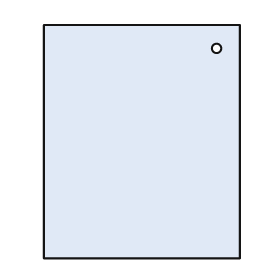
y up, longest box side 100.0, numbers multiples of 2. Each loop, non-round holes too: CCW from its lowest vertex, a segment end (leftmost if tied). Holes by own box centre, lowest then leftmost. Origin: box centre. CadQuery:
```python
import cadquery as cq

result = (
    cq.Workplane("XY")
    .moveTo(-42.0, -50.0)
    .lineTo(42.0, -50.0)
    .lineTo(42.0, 50.0)
    .lineTo(-42.0, 50.0)
    .close()
    .moveTo(32.0, 40.0)
    .circle(2.0)
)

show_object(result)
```